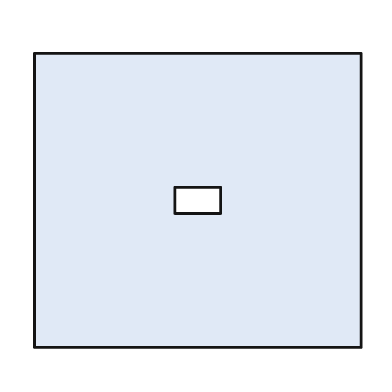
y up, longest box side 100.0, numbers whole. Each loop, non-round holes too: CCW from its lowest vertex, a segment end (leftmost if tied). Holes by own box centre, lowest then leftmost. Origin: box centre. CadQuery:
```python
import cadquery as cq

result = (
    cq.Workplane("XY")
    .moveTo(-50.0, -45.0)
    .lineTo(50.0, -45.0)
    .lineTo(50.0, 45.0)
    .lineTo(-50.0, 45.0)
    .close()
    .moveTo(-7.0, -4.0)
    .lineTo(7.0, -4.0)
    .lineTo(7.0, 4.0)
    .lineTo(-7.0, 4.0)
    .close()
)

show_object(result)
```